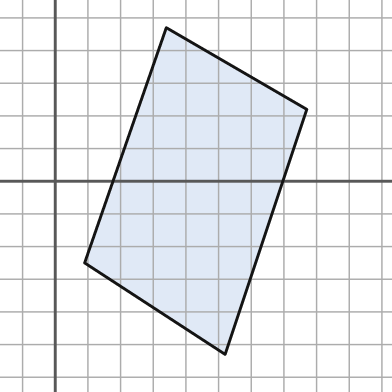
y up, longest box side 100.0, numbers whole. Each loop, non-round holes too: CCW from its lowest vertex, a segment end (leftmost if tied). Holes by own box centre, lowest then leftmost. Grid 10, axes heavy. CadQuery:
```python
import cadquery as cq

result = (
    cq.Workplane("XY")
    .moveTo(52.0, -53.0)
    .lineTo(77.0, 22.0)
    .lineTo(34.0, 47.0)
    .lineTo(9.0, -25.0)
    .close()
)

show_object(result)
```